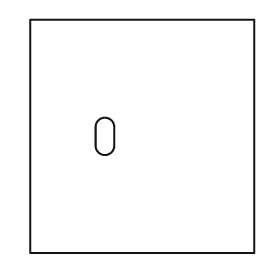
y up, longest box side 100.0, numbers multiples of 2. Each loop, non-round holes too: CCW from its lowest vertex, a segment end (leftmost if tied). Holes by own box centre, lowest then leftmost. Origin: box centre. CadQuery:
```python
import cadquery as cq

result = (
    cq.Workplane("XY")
    .moveTo(-48.0, -50.0)
    .lineTo(48.0, -50.0)
    .lineTo(48.0, 50.0)
    .lineTo(-48.0, 50.0)
    .close()
    .moveTo(-20.0, -4.0)
    .threePointArc((-16.0, -8.0), (-12.0, -4.0))
    .lineTo(-12.0, 4.0)
    .threePointArc((-16.0, 8.0), (-20.0, 4.0))
    .close()
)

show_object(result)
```